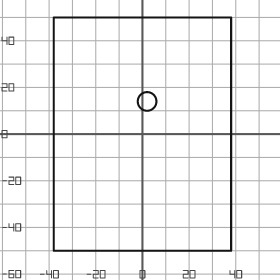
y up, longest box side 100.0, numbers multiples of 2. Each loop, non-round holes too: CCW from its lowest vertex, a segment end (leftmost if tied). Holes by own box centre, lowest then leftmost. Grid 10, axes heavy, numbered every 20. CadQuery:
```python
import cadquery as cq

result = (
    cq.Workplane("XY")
    .moveTo(-38.0, -50.0)
    .lineTo(38.0, -50.0)
    .lineTo(38.0, 50.0)
    .lineTo(-38.0, 50.0)
    .close()
    .moveTo(2.0, 14.0)
    .circle(4.0)
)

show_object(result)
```